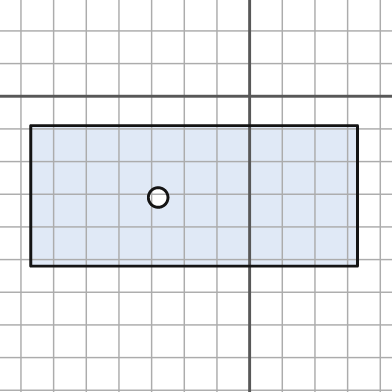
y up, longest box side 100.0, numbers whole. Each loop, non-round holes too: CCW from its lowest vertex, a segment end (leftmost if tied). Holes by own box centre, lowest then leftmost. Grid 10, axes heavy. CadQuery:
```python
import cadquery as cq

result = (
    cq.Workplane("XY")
    .moveTo(-67.0, -52.0)
    .lineTo(33.0, -52.0)
    .lineTo(33.0, -9.0)
    .lineTo(-67.0, -9.0)
    .close()
    .moveTo(-28.0, -31.0)
    .circle(3.0)
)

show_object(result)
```